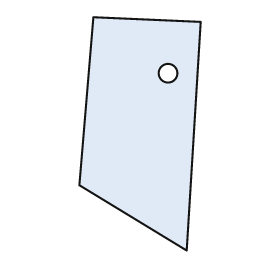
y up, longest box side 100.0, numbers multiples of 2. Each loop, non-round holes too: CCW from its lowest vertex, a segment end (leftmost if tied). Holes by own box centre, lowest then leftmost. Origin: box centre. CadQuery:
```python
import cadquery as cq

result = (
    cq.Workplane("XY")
    .moveTo(20.0, -50.0)
    .lineTo(26.0, 48.0)
    .lineTo(-20.0, 50.0)
    .lineTo(-26.0, -22.0)
    .close()
    .moveTo(12.0, 26.0)
    .circle(4.0)
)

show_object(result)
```